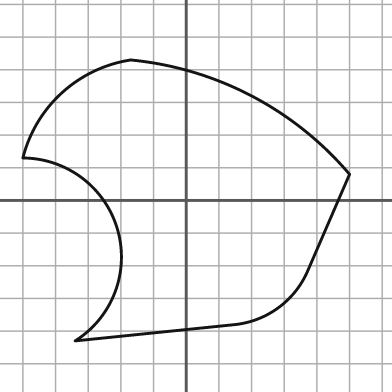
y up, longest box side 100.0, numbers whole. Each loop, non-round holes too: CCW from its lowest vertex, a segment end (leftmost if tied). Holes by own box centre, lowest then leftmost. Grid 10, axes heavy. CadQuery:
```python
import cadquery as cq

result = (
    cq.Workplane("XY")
    .moveTo(-34.0, -43.0)
    .lineTo(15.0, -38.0)
    .threePointArc((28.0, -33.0), (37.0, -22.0))
    .lineTo(50.0, 8.0)
    .threePointArc((20.0, 32.0), (-17.0, 43.0))
    .threePointArc((-38.0, 33.0), (-50.0, 13.0))
    .threePointArc((-21.0, -9.0), (-34.0, -43.0))
    .close()
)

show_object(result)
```